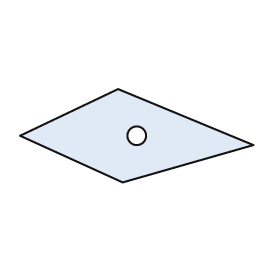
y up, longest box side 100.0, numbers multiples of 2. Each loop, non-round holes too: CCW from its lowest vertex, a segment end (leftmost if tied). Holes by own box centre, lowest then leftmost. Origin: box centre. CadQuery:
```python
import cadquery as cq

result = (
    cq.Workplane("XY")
    .moveTo(-6.0, -20.0)
    .lineTo(50.0, -4.0)
    .lineTo(-8.0, 20.0)
    .lineTo(-50.0, 0.0)
    .close()
    .moveTo(0.0, 0.0)
    .circle(4.0)
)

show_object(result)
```